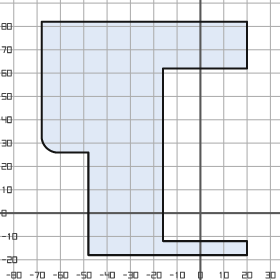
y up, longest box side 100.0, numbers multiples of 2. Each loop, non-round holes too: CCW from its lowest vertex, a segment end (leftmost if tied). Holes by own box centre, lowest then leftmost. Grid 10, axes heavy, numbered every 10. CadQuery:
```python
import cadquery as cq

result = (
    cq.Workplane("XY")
    .moveTo(-48.0, -18.0)
    .lineTo(20.0, -18.0)
    .lineTo(20.0, -12.0)
    .lineTo(-16.0, -12.0)
    .lineTo(-16.0, 62.0)
    .lineTo(20.0, 62.0)
    .lineTo(20.0, 82.0)
    .lineTo(-68.0, 82.0)
    .lineTo(-68.0, 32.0)
    .threePointArc((-66.0, 28.0), (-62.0, 26.0))
    .lineTo(-48.0, 26.0)
    .close()
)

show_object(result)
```